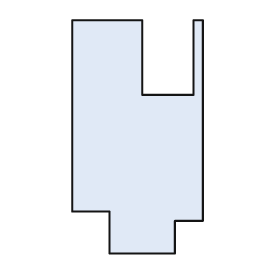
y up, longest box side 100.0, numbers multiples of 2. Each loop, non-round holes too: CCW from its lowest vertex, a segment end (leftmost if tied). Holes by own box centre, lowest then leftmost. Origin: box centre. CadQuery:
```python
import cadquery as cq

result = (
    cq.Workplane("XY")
    .moveTo(-12.0, -50.0)
    .lineTo(16.0, -50.0)
    .lineTo(16.0, -36.0)
    .lineTo(28.0, -36.0)
    .lineTo(28.0, 50.0)
    .lineTo(24.0, 50.0)
    .lineTo(24.0, 18.0)
    .lineTo(2.0, 18.0)
    .lineTo(2.0, 50.0)
    .lineTo(-28.0, 50.0)
    .lineTo(-28.0, -32.0)
    .lineTo(-12.0, -32.0)
    .close()
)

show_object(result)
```